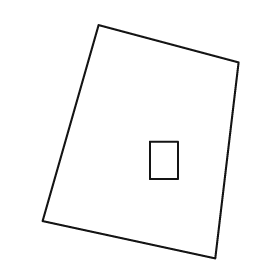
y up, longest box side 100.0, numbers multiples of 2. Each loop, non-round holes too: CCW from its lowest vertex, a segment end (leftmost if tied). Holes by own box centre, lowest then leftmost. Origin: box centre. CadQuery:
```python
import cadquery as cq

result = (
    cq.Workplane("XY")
    .moveTo(32.0, -50.0)
    .lineTo(42.0, 34.0)
    .lineTo(-18.0, 50.0)
    .lineTo(-42.0, -34.0)
    .close()
    .moveTo(4.0, -16.0)
    .lineTo(16.0, -16.0)
    .lineTo(16.0, 0.0)
    .lineTo(4.0, 0.0)
    .close()
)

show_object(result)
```